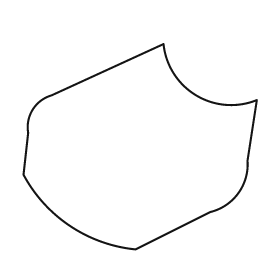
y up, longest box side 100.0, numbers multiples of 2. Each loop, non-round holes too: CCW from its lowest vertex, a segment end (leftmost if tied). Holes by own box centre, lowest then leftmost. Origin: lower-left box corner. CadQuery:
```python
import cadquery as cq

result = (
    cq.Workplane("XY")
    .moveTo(48.0, 0.0)
    .lineTo(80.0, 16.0)
    .threePointArc((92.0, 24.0), (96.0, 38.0))
    .lineTo(100.0, 64.0)
    .threePointArc((74.0, 66.0), (60.0, 88.0))
    .lineTo(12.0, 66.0)
    .threePointArc((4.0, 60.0), (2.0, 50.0))
    .lineTo(0.0, 32.0)
    .threePointArc((20.0, 10.0), (48.0, 0.0))
    .close()
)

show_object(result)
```